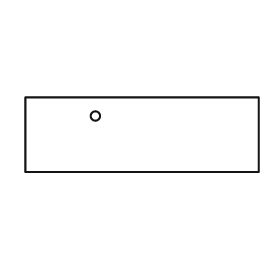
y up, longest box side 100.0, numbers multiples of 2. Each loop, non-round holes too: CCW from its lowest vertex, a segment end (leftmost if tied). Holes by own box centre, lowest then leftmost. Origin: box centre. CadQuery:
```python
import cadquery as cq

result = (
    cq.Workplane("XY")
    .moveTo(-50.0, -16.0)
    .lineTo(50.0, -16.0)
    .lineTo(50.0, 16.0)
    .lineTo(-50.0, 16.0)
    .close()
    .moveTo(-20.0, 8.0)
    .circle(2.0)
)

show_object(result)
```